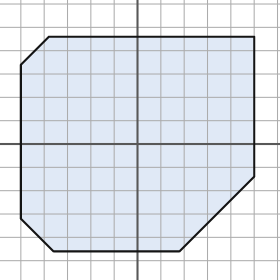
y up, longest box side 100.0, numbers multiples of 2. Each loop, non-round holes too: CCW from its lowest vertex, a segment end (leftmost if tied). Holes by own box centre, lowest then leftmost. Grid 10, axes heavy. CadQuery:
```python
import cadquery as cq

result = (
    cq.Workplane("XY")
    .moveTo(-36.0, -46.0)
    .lineTo(18.0, -46.0)
    .lineTo(50.0, -14.0)
    .lineTo(50.0, 46.0)
    .lineTo(-38.0, 46.0)
    .lineTo(-50.0, 34.0)
    .lineTo(-50.0, -32.0)
    .close()
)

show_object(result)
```